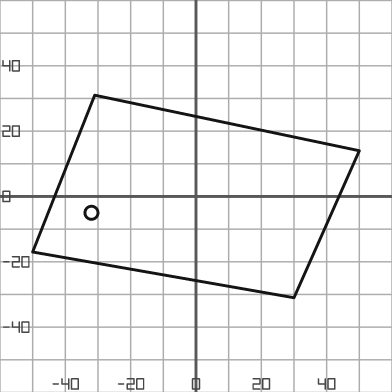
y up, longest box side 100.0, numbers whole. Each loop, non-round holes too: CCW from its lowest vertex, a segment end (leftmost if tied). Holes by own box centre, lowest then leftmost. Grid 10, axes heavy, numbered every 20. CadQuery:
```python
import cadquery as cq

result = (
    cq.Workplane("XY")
    .moveTo(30.0, -31.0)
    .lineTo(50.0, 14.0)
    .lineTo(-31.0, 31.0)
    .lineTo(-50.0, -17.0)
    .close()
    .moveTo(-32.0, -5.0)
    .circle(2.0)
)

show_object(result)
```